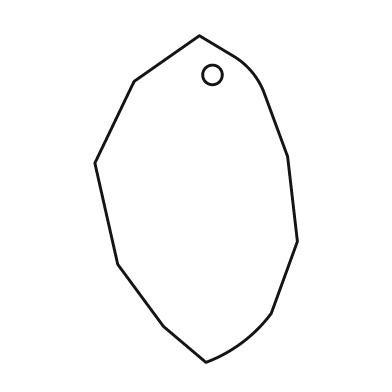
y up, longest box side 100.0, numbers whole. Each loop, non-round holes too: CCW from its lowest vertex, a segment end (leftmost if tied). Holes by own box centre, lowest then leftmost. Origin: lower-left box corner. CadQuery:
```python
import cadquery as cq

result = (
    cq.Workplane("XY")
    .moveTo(34.0, 0.0)
    .threePointArc((45.0, 6.0), (54.0, 15.0))
    .lineTo(62.0, 37.0)
    .lineTo(59.0, 63.0)
    .lineTo(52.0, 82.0)
    .threePointArc((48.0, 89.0), (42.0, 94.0))
    .lineTo(32.0, 100.0)
    .lineTo(12.0, 86.0)
    .lineTo(0.0, 61.0)
    .lineTo(7.0, 30.0)
    .lineTo(21.0, 11.0)
    .close()
    .moveTo(36.0, 88.0)
    .circle(3.0)
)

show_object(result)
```